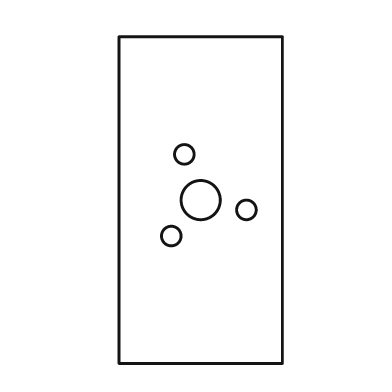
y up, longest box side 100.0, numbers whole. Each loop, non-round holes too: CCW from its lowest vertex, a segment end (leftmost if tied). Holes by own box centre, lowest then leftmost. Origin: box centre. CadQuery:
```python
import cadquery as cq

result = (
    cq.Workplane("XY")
    .moveTo(-25.0, -50.0)
    .lineTo(25.0, -50.0)
    .lineTo(25.0, 50.0)
    .lineTo(-25.0, 50.0)
    .close()
    .moveTo(-9.0, -11.0)
    .circle(3.0)
    .moveTo(14.0, -3.0)
    .circle(3.0)
    .moveTo(0.0, 0.0)
    .circle(6.0)
    .moveTo(-5.0, 14.0)
    .circle(3.0)
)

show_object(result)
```